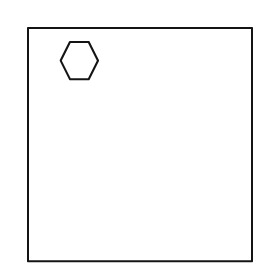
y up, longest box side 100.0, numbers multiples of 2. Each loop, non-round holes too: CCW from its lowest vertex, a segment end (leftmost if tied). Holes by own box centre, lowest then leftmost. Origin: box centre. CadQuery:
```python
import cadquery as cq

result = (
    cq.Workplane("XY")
    .moveTo(-48.0, -50.0)
    .lineTo(48.0, -50.0)
    .lineTo(48.0, 50.0)
    .lineTo(-48.0, 50.0)
    .close()
    .moveTo(-30.0, 28.0)
    .lineTo(-22.0, 28.0)
    .lineTo(-18.0, 36.0)
    .lineTo(-22.0, 44.0)
    .lineTo(-30.0, 44.0)
    .lineTo(-34.0, 36.0)
    .close()
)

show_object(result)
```